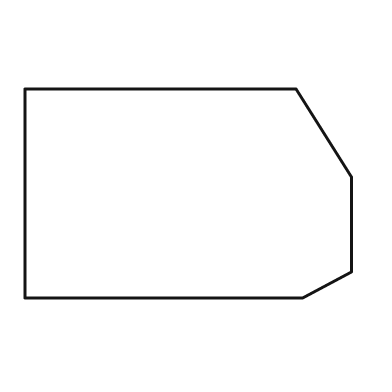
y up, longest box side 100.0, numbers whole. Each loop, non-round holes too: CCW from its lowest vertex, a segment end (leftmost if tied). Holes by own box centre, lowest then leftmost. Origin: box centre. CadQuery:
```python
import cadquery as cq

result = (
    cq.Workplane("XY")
    .moveTo(-50.0, -32.0)
    .lineTo(35.0, -32.0)
    .lineTo(50.0, -24.0)
    .lineTo(50.0, 5.0)
    .lineTo(33.0, 32.0)
    .lineTo(-50.0, 32.0)
    .close()
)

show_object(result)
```